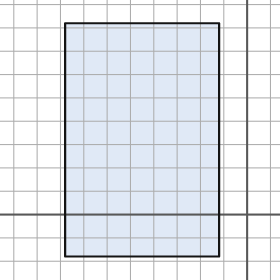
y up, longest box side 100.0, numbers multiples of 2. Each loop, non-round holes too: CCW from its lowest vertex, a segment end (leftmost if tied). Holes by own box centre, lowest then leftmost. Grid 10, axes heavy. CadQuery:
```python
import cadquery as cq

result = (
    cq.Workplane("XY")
    .moveTo(-78.0, -18.0)
    .lineTo(-12.0, -18.0)
    .lineTo(-12.0, 82.0)
    .lineTo(-78.0, 82.0)
    .close()
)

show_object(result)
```